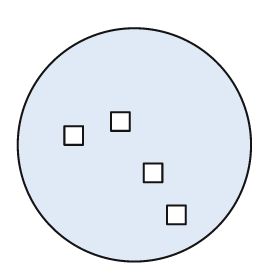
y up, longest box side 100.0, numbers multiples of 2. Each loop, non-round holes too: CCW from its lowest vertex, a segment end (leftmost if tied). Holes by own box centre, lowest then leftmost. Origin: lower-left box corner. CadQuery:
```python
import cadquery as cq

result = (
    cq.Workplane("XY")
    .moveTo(50.0, 50.0)
    .circle(50.0)
    .moveTo(64.0, 16.0)
    .lineTo(72.0, 16.0)
    .lineTo(72.0, 24.0)
    .lineTo(64.0, 24.0)
    .close()
    .moveTo(54.0, 34.0)
    .lineTo(62.0, 34.0)
    .lineTo(62.0, 42.0)
    .lineTo(54.0, 42.0)
    .close()
    .moveTo(20.0, 50.0)
    .lineTo(28.0, 50.0)
    .lineTo(28.0, 58.0)
    .lineTo(20.0, 58.0)
    .close()
    .moveTo(40.0, 56.0)
    .lineTo(48.0, 56.0)
    .lineTo(48.0, 64.0)
    .lineTo(40.0, 64.0)
    .close()
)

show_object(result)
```